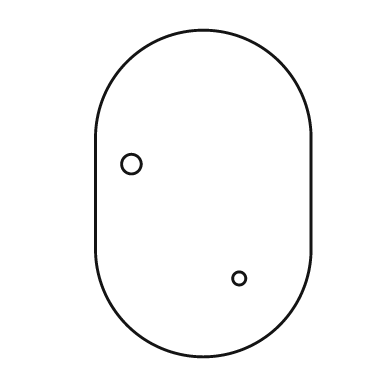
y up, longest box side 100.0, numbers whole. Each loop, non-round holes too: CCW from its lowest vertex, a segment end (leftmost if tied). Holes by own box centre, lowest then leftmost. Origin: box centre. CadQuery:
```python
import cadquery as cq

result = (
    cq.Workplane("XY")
    .moveTo(-33.0, -17.0)
    .threePointArc((0.0, -50.0), (33.0, -17.0))
    .lineTo(33.0, 17.0)
    .threePointArc((0.0, 50.0), (-33.0, 17.0))
    .close()
    .moveTo(11.0, -26.0)
    .circle(2.0)
    .moveTo(-22.0, 9.0)
    .circle(3.0)
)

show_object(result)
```